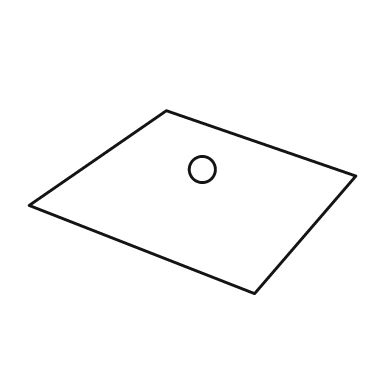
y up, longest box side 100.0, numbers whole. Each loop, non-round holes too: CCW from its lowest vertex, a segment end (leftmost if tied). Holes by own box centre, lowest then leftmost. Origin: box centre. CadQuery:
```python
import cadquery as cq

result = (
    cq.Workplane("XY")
    .moveTo(19.0, -28.0)
    .lineTo(50.0, 8.0)
    .lineTo(-8.0, 28.0)
    .lineTo(-50.0, -1.0)
    .close()
    .moveTo(3.0, 10.0)
    .circle(4.0)
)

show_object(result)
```